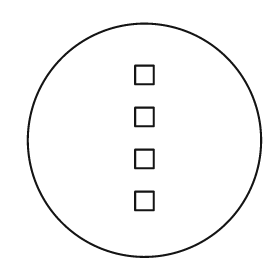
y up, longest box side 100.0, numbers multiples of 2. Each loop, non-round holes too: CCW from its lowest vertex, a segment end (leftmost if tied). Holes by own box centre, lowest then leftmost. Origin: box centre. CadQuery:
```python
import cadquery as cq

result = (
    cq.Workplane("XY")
    .moveTo(0.0, 0.0)
    .circle(50.0)
    .moveTo(-4.0, -30.0)
    .lineTo(4.0, -30.0)
    .lineTo(4.0, -22.0)
    .lineTo(-4.0, -22.0)
    .close()
    .moveTo(-4.0, -12.0)
    .lineTo(4.0, -12.0)
    .lineTo(4.0, -4.0)
    .lineTo(-4.0, -4.0)
    .close()
    .moveTo(-4.0, 6.0)
    .lineTo(4.0, 6.0)
    .lineTo(4.0, 14.0)
    .lineTo(-4.0, 14.0)
    .close()
    .moveTo(-4.0, 24.0)
    .lineTo(4.0, 24.0)
    .lineTo(4.0, 32.0)
    .lineTo(-4.0, 32.0)
    .close()
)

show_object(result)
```